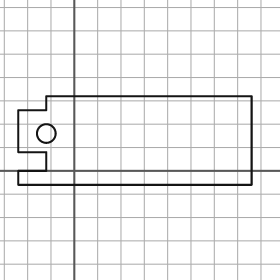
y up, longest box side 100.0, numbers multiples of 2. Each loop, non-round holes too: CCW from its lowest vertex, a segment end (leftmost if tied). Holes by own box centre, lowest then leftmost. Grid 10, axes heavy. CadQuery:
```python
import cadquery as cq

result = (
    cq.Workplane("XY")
    .moveTo(-24.0, -6.0)
    .lineTo(76.0, -6.0)
    .lineTo(76.0, 32.0)
    .lineTo(-12.0, 32.0)
    .lineTo(-12.0, 26.0)
    .lineTo(-24.0, 26.0)
    .lineTo(-24.0, 8.0)
    .lineTo(-12.0, 8.0)
    .lineTo(-12.0, 0.0)
    .lineTo(-24.0, 0.0)
    .close()
    .moveTo(-12.0, 16.0)
    .circle(4.0)
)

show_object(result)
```